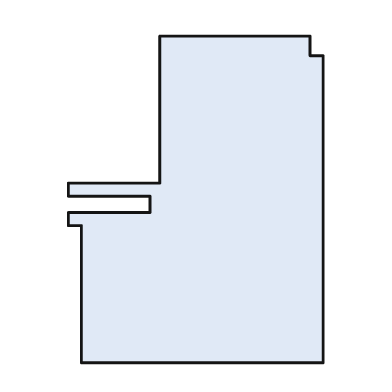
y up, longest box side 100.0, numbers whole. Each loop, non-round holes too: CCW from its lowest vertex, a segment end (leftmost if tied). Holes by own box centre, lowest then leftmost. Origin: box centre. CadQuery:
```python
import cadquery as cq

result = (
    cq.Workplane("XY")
    .moveTo(-35.0, -50.0)
    .lineTo(39.0, -50.0)
    .lineTo(39.0, 44.0)
    .lineTo(35.0, 44.0)
    .lineTo(35.0, 50.0)
    .lineTo(-11.0, 50.0)
    .lineTo(-11.0, 5.0)
    .lineTo(-39.0, 5.0)
    .lineTo(-39.0, 1.0)
    .lineTo(-14.0, 1.0)
    .lineTo(-14.0, -4.0)
    .lineTo(-39.0, -4.0)
    .lineTo(-39.0, -8.0)
    .lineTo(-35.0, -8.0)
    .close()
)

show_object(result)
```